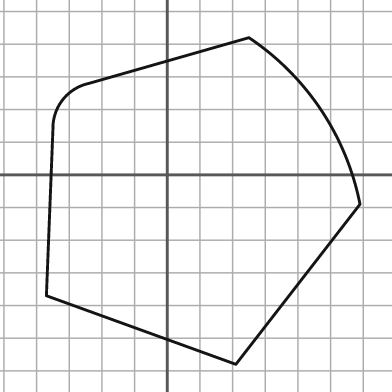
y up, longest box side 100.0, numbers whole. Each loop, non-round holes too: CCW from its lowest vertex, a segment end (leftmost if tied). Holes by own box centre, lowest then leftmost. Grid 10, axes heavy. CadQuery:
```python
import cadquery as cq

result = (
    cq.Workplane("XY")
    .moveTo(21.0, -58.0)
    .lineTo(59.0, -9.0)
    .threePointArc((47.0, 20.0), (25.0, 42.0))
    .lineTo(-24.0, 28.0)
    .threePointArc((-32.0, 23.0), (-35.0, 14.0))
    .lineTo(-37.0, -37.0)
    .close()
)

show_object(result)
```